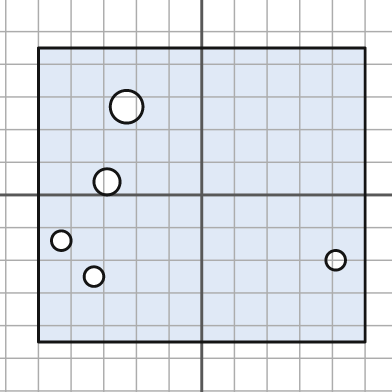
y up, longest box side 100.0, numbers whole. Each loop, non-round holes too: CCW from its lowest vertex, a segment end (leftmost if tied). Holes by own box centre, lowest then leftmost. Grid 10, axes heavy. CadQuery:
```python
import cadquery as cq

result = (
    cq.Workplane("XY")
    .moveTo(-50.0, -45.0)
    .lineTo(50.0, -45.0)
    .lineTo(50.0, 45.0)
    .lineTo(-50.0, 45.0)
    .close()
    .moveTo(-33.0, -25.0)
    .circle(3.0)
    .moveTo(41.0, -20.0)
    .circle(3.0)
    .moveTo(-43.0, -14.0)
    .circle(3.0)
    .moveTo(-29.0, 4.0)
    .circle(4.0)
    .moveTo(-23.0, 27.0)
    .circle(5.0)
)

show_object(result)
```